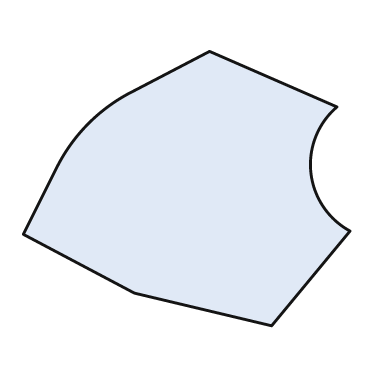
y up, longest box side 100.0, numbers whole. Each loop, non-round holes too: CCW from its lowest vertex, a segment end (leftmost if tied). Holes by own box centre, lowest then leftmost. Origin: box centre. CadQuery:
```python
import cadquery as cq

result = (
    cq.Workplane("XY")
    .moveTo(26.0, -42.0)
    .lineTo(50.0, -13.0)
    .threePointArc((38.0, 5.0), (46.0, 25.0))
    .lineTo(7.0, 42.0)
    .lineTo(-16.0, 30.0)
    .threePointArc((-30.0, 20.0), (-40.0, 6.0))
    .lineTo(-50.0, -14.0)
    .lineTo(-16.0, -32.0)
    .close()
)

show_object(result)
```